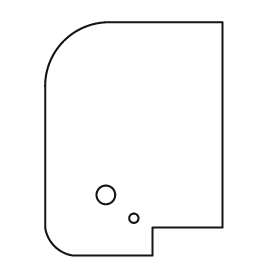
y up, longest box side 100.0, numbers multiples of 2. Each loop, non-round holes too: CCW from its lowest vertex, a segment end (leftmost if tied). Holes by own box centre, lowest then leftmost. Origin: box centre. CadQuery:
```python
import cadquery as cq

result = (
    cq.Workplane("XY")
    .moveTo(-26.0, -50.0)
    .lineTo(8.0, -50.0)
    .lineTo(8.0, -38.0)
    .lineTo(38.0, -38.0)
    .lineTo(38.0, 50.0)
    .lineTo(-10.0, 50.0)
    .threePointArc((-30.0, 42.0), (-38.0, 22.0))
    .lineTo(-38.0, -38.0)
    .threePointArc((-34.0, -46.0), (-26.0, -50.0))
    .close()
    .moveTo(0.0, -34.0)
    .circle(2.0)
    .moveTo(-12.0, -24.0)
    .circle(4.0)
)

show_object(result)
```